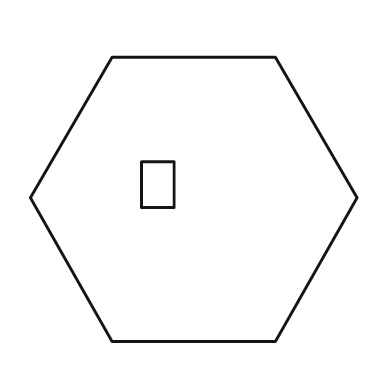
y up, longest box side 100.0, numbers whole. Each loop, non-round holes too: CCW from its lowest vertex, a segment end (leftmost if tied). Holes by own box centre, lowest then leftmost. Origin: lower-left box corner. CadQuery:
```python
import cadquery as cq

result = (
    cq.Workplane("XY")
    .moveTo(25.0, 0.0)
    .lineTo(75.0, 0.0)
    .lineTo(100.0, 44.0)
    .lineTo(75.0, 87.0)
    .lineTo(25.0, 87.0)
    .lineTo(0.0, 44.0)
    .close()
    .moveTo(34.0, 41.0)
    .lineTo(44.0, 41.0)
    .lineTo(44.0, 55.0)
    .lineTo(34.0, 55.0)
    .close()
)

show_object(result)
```